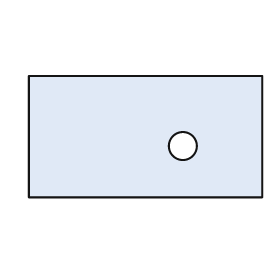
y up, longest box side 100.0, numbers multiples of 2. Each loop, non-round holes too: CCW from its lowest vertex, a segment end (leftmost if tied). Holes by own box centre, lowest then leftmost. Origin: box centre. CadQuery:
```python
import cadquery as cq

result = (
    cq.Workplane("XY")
    .moveTo(-50.0, -26.0)
    .lineTo(50.0, -26.0)
    .lineTo(50.0, 26.0)
    .lineTo(-50.0, 26.0)
    .close()
    .moveTo(16.0, -4.0)
    .circle(6.0)
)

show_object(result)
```